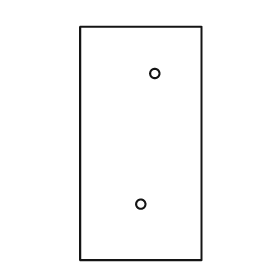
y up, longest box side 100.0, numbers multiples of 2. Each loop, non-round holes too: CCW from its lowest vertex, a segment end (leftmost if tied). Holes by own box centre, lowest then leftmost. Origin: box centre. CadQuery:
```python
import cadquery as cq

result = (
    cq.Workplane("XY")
    .moveTo(-26.0, -50.0)
    .lineTo(26.0, -50.0)
    .lineTo(26.0, 50.0)
    .lineTo(-26.0, 50.0)
    .close()
    .moveTo(0.0, -26.0)
    .circle(2.0)
    .moveTo(6.0, 30.0)
    .circle(2.0)
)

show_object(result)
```